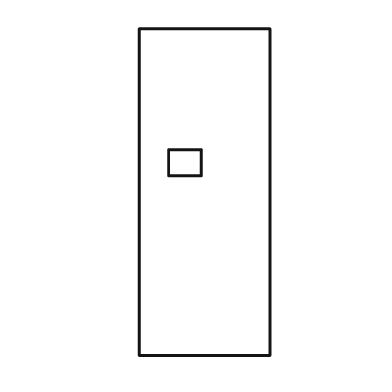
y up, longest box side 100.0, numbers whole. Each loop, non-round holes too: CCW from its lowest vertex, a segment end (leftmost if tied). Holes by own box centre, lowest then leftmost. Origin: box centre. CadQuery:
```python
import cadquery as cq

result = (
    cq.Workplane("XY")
    .moveTo(-20.0, -50.0)
    .lineTo(20.0, -50.0)
    .lineTo(20.0, 50.0)
    .lineTo(-20.0, 50.0)
    .close()
    .moveTo(-11.0, 5.0)
    .lineTo(-1.0, 5.0)
    .lineTo(-1.0, 13.0)
    .lineTo(-11.0, 13.0)
    .close()
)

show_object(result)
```